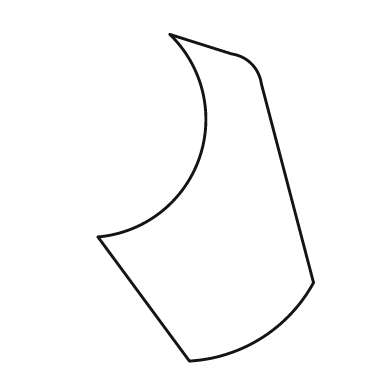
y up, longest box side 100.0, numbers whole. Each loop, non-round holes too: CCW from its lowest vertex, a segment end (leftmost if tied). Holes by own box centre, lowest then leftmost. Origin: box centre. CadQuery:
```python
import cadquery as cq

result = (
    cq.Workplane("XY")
    .moveTo(-5.0, -50.0)
    .threePointArc((17.0, -43.0), (33.0, -26.0))
    .lineTo(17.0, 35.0)
    .threePointArc((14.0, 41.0), (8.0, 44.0))
    .lineTo(-11.0, 50.0)
    .threePointArc((-2.0, 12.0), (-33.0, -12.0))
    .close()
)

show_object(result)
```